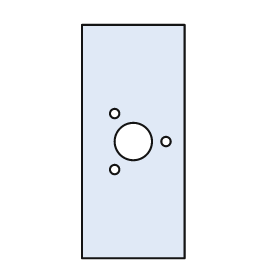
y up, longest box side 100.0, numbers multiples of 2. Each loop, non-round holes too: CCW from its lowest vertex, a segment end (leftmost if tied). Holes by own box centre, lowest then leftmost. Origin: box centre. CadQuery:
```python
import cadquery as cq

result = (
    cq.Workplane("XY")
    .moveTo(-22.0, -50.0)
    .lineTo(22.0, -50.0)
    .lineTo(22.0, 50.0)
    .lineTo(-22.0, 50.0)
    .close()
    .moveTo(-8.0, -12.0)
    .circle(2.0)
    .moveTo(0.0, 0.0)
    .circle(8.0)
    .moveTo(14.0, 0.0)
    .circle(2.0)
    .moveTo(-8.0, 12.0)
    .circle(2.0)
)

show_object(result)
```